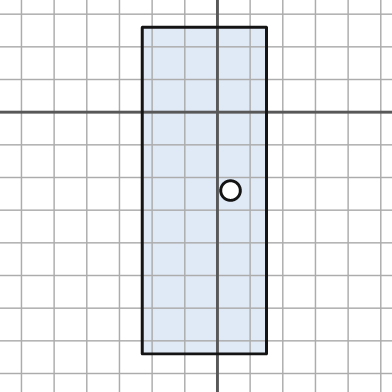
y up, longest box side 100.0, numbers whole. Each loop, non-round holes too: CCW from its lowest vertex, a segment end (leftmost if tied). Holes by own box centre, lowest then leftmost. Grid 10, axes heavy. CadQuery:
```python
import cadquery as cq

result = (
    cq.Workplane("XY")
    .moveTo(-23.0, -74.0)
    .lineTo(15.0, -74.0)
    .lineTo(15.0, 26.0)
    .lineTo(-23.0, 26.0)
    .close()
    .moveTo(4.0, -24.0)
    .circle(3.0)
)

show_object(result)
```